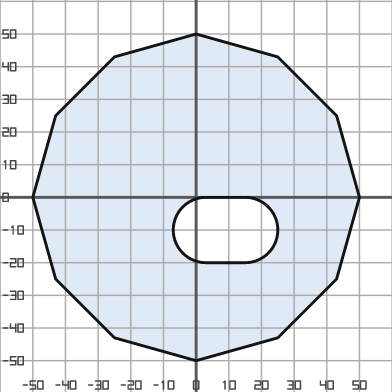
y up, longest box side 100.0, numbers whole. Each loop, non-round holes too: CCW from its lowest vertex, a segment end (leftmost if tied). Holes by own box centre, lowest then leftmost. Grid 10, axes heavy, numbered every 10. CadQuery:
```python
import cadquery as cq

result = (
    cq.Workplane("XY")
    .moveTo(0.0, -50.0)
    .lineTo(25.0, -43.0)
    .lineTo(43.0, -25.0)
    .lineTo(50.0, 0.0)
    .lineTo(43.0, 25.0)
    .lineTo(25.0, 43.0)
    .lineTo(0.0, 50.0)
    .lineTo(-25.0, 43.0)
    .lineTo(-43.0, 25.0)
    .lineTo(-50.0, 0.0)
    .lineTo(-43.0, -25.0)
    .lineTo(-25.0, -43.0)
    .close()
    .moveTo(3.0, -20.0)
    .lineTo(15.0, -20.0)
    .threePointArc((25.0, -10.0), (15.0, 0.0))
    .lineTo(3.0, 0.0)
    .threePointArc((-7.0, -10.0), (3.0, -20.0))
    .close()
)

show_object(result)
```